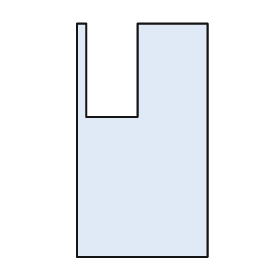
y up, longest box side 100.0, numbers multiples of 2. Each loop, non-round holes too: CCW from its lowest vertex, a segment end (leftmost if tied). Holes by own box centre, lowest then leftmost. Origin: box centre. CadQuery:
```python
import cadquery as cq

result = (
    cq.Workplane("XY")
    .moveTo(-28.0, -50.0)
    .lineTo(28.0, -50.0)
    .lineTo(28.0, 50.0)
    .lineTo(-2.0, 50.0)
    .lineTo(-2.0, 10.0)
    .lineTo(-24.0, 10.0)
    .lineTo(-24.0, 50.0)
    .lineTo(-28.0, 50.0)
    .close()
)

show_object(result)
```